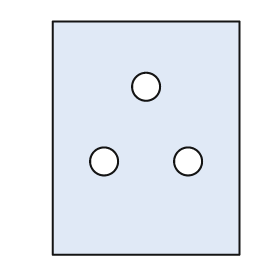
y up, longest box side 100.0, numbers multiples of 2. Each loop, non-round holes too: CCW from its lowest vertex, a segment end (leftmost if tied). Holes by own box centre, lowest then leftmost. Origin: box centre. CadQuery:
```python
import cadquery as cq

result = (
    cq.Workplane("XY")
    .moveTo(-40.0, -50.0)
    .lineTo(40.0, -50.0)
    .lineTo(40.0, 50.0)
    .lineTo(-40.0, 50.0)
    .close()
    .moveTo(-18.0, -10.0)
    .circle(6.0)
    .moveTo(18.0, -10.0)
    .circle(6.0)
    .moveTo(0.0, 22.0)
    .circle(6.0)
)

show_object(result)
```